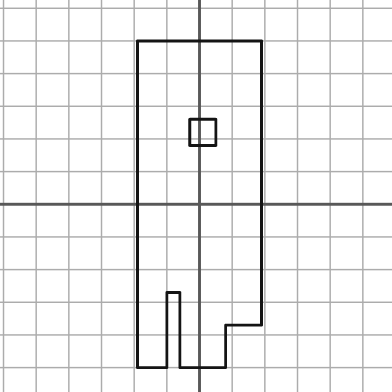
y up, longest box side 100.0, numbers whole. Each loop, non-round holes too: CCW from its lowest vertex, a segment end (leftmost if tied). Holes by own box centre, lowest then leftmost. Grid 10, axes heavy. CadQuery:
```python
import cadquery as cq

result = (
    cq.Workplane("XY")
    .moveTo(-19.0, -50.0)
    .lineTo(-10.0, -50.0)
    .lineTo(-10.0, -27.0)
    .lineTo(-6.0, -27.0)
    .lineTo(-6.0, -50.0)
    .lineTo(8.0, -50.0)
    .lineTo(8.0, -37.0)
    .lineTo(19.0, -37.0)
    .lineTo(19.0, 50.0)
    .lineTo(-19.0, 50.0)
    .close()
    .moveTo(-3.0, 18.0)
    .lineTo(5.0, 18.0)
    .lineTo(5.0, 26.0)
    .lineTo(-3.0, 26.0)
    .close()
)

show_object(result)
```